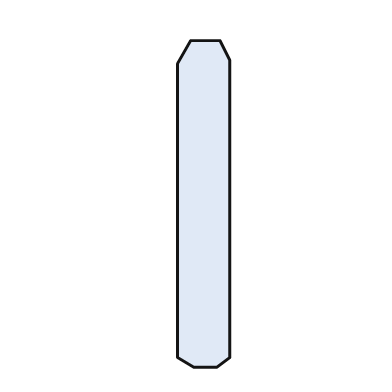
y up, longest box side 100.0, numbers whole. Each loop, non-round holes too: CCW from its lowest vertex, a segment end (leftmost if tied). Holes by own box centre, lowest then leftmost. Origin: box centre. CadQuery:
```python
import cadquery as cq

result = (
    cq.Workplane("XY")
    .moveTo(-3.0, -50.0)
    .lineTo(4.0, -50.0)
    .lineTo(8.0, -47.0)
    .lineTo(8.0, 44.0)
    .lineTo(5.0, 50.0)
    .lineTo(-4.0, 50.0)
    .lineTo(-8.0, 43.0)
    .lineTo(-8.0, -47.0)
    .close()
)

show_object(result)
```